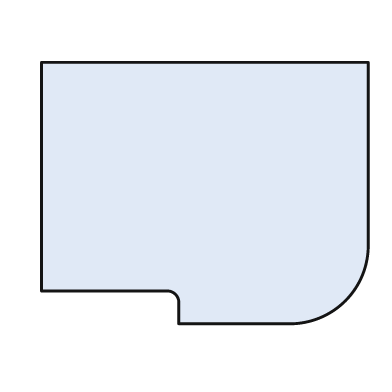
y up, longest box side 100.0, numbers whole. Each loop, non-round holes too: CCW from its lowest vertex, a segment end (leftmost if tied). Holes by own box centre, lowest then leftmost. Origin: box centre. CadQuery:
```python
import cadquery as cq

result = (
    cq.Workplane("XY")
    .moveTo(-8.0, -40.0)
    .lineTo(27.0, -40.0)
    .threePointArc((43.0, -33.0), (50.0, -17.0))
    .lineTo(50.0, 40.0)
    .lineTo(-50.0, 40.0)
    .lineTo(-50.0, -30.0)
    .lineTo(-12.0, -30.0)
    .threePointArc((-9.0, -31.0), (-8.0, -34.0))
    .close()
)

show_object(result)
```